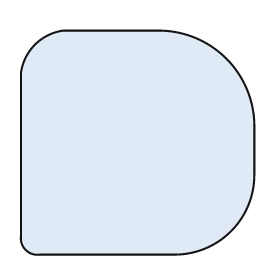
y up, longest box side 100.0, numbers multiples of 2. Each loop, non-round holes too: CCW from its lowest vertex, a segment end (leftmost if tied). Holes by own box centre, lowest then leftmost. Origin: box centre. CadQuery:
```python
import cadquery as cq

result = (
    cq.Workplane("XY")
    .moveTo(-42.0, -48.0)
    .lineTo(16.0, -48.0)
    .threePointArc((40.0, -38.0), (50.0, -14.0))
    .lineTo(50.0, 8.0)
    .threePointArc((38.0, 36.0), (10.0, 48.0))
    .lineTo(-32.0, 48.0)
    .threePointArc((-44.0, 42.0), (-50.0, 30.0))
    .lineTo(-50.0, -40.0)
    .threePointArc((-48.0, -46.0), (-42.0, -48.0))
    .close()
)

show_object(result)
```